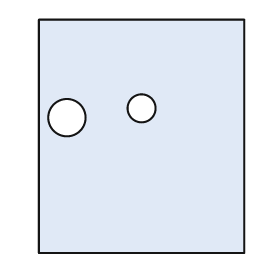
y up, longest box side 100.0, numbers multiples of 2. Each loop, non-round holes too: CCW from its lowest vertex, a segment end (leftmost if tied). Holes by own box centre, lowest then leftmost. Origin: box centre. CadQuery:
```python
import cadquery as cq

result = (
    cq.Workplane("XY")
    .moveTo(-44.0, -50.0)
    .lineTo(44.0, -50.0)
    .lineTo(44.0, 50.0)
    .lineTo(-44.0, 50.0)
    .close()
    .moveTo(-32.0, 8.0)
    .circle(8.0)
    .moveTo(0.0, 12.0)
    .circle(6.0)
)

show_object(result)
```